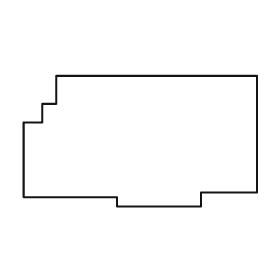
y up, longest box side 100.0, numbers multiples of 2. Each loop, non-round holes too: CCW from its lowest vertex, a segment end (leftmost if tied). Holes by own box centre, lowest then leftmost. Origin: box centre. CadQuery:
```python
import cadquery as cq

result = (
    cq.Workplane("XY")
    .moveTo(-10.0, -28.0)
    .lineTo(26.0, -28.0)
    .lineTo(26.0, -22.0)
    .lineTo(50.0, -22.0)
    .lineTo(50.0, 28.0)
    .lineTo(-36.0, 28.0)
    .lineTo(-36.0, 16.0)
    .lineTo(-42.0, 16.0)
    .lineTo(-42.0, 8.0)
    .lineTo(-50.0, 8.0)
    .lineTo(-50.0, -24.0)
    .lineTo(-10.0, -24.0)
    .close()
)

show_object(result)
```